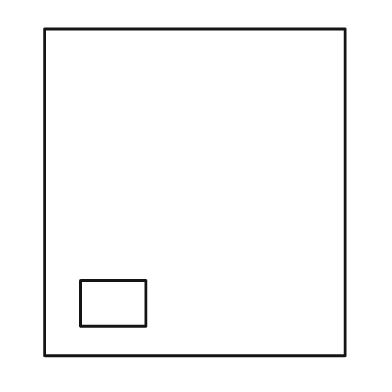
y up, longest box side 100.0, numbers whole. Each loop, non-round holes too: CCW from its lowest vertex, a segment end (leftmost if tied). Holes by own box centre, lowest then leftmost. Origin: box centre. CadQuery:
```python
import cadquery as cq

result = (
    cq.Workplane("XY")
    .moveTo(-46.0, -50.0)
    .lineTo(46.0, -50.0)
    .lineTo(46.0, 50.0)
    .lineTo(-46.0, 50.0)
    .close()
    .moveTo(-35.0, -41.0)
    .lineTo(-15.0, -41.0)
    .lineTo(-15.0, -27.0)
    .lineTo(-35.0, -27.0)
    .close()
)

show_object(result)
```